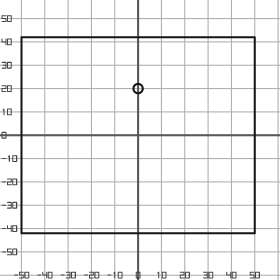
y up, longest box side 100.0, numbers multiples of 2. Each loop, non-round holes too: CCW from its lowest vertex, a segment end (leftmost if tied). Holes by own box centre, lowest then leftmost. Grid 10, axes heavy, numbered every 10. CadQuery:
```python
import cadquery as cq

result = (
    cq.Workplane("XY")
    .moveTo(-50.0, -42.0)
    .lineTo(50.0, -42.0)
    .lineTo(50.0, 42.0)
    .lineTo(-50.0, 42.0)
    .close()
    .moveTo(0.0, 20.0)
    .circle(2.0)
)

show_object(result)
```